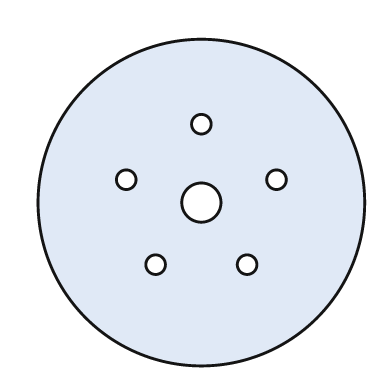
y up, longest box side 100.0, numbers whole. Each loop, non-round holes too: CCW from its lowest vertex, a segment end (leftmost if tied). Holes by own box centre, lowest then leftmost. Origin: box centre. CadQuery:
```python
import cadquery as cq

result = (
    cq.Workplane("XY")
    .moveTo(0.0, 0.0)
    .circle(50.0)
    .moveTo(-14.0, -19.0)
    .circle(3.0)
    .moveTo(14.0, -19.0)
    .circle(3.0)
    .moveTo(0.0, 0.0)
    .circle(6.0)
    .moveTo(-23.0, 7.0)
    .circle(3.0)
    .moveTo(23.0, 7.0)
    .circle(3.0)
    .moveTo(0.0, 24.0)
    .circle(3.0)
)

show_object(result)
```